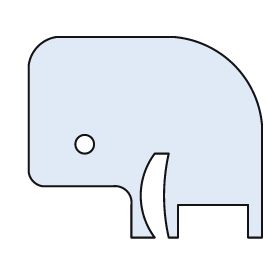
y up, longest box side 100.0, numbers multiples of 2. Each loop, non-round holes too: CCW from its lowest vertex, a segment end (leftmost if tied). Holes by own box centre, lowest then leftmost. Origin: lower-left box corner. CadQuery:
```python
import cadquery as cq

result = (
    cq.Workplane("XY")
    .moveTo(44.0, 0.0)
    .lineTo(54.0, 0.0)
    .threePointArc((48.0, 18.0), (54.0, 36.0))
    .lineTo(60.0, 36.0)
    .threePointArc((58.0, 18.0), (60.0, 0.0))
    .lineTo(64.0, 0.0)
    .lineTo(64.0, 14.0)
    .lineTo(94.0, 14.0)
    .lineTo(94.0, 0.0)
    .lineTo(100.0, 0.0)
    .lineTo(100.0, 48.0)
    .threePointArc((88.0, 74.0), (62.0, 86.0))
    .lineTo(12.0, 86.0)
    .threePointArc((4.0, 82.0), (0.0, 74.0))
    .lineTo(0.0, 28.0)
    .threePointArc((2.0, 24.0), (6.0, 22.0))
    .lineTo(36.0, 22.0)
    .threePointArc((42.0, 20.0), (44.0, 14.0))
    .close()
    .moveTo(24.0, 40.0)
    .circle(4.0)
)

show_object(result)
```